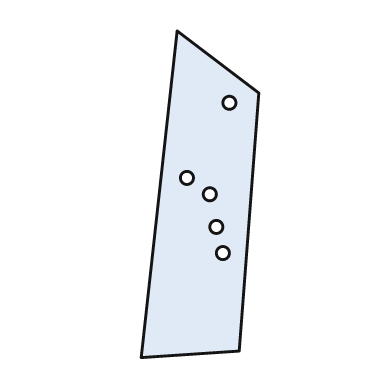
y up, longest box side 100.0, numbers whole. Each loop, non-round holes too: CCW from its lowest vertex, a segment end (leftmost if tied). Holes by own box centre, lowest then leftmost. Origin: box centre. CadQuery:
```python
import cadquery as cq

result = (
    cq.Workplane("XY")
    .moveTo(-18.0, -50.0)
    .lineTo(12.0, -48.0)
    .lineTo(18.0, 31.0)
    .lineTo(-7.0, 50.0)
    .close()
    .moveTo(7.0, -18.0)
    .circle(2.0)
    .moveTo(5.0, -10.0)
    .circle(2.0)
    .moveTo(3.0, 0.0)
    .circle(2.0)
    .moveTo(-4.0, 5.0)
    .circle(2.0)
    .moveTo(9.0, 28.0)
    .circle(2.0)
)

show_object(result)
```